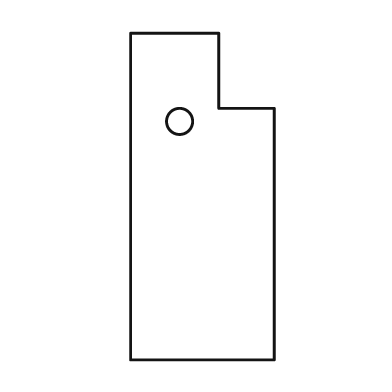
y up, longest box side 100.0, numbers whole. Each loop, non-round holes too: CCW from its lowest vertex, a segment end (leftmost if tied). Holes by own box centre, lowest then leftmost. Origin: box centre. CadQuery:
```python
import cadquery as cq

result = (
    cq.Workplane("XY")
    .moveTo(-22.0, -50.0)
    .lineTo(22.0, -50.0)
    .lineTo(22.0, 27.0)
    .lineTo(5.0, 27.0)
    .lineTo(5.0, 50.0)
    .lineTo(-22.0, 50.0)
    .close()
    .moveTo(-7.0, 23.0)
    .circle(4.0)
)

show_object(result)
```